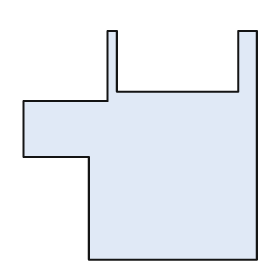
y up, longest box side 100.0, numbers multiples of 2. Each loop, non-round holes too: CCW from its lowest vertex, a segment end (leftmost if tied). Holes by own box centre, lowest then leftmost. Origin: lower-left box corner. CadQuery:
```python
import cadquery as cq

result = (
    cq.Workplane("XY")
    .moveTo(28.0, 0.0)
    .lineTo(100.0, 0.0)
    .lineTo(100.0, 98.0)
    .lineTo(92.0, 98.0)
    .lineTo(92.0, 72.0)
    .lineTo(40.0, 72.0)
    .lineTo(40.0, 98.0)
    .lineTo(36.0, 98.0)
    .lineTo(36.0, 68.0)
    .lineTo(0.0, 68.0)
    .lineTo(0.0, 44.0)
    .lineTo(28.0, 44.0)
    .close()
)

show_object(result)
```